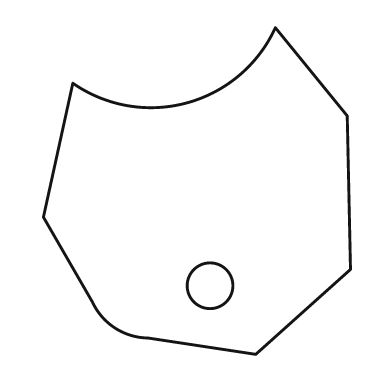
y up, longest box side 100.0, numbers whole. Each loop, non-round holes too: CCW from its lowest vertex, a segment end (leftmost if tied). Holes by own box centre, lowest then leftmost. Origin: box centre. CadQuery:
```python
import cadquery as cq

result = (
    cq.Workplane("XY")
    .moveTo(18.0, -50.0)
    .lineTo(47.0, -24.0)
    .lineTo(46.0, 23.0)
    .lineTo(24.0, 50.0)
    .threePointArc((-3.0, 27.0), (-38.0, 33.0))
    .lineTo(-47.0, -8.0)
    .lineTo(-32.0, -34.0)
    .threePointArc((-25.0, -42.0), (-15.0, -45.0))
    .close()
    .moveTo(4.0, -29.0)
    .circle(7.0)
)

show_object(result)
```